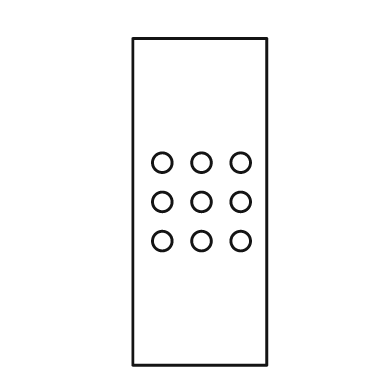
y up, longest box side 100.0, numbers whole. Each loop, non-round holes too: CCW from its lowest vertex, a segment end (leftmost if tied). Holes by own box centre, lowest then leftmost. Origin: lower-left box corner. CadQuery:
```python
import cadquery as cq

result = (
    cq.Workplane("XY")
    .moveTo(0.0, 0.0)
    .lineTo(41.0, 0.0)
    .lineTo(41.0, 100.0)
    .lineTo(0.0, 100.0)
    .close()
    .moveTo(9.0, 38.0)
    .circle(3.0)
    .moveTo(21.0, 38.0)
    .circle(3.0)
    .moveTo(33.0, 38.0)
    .circle(3.0)
    .moveTo(9.0, 50.0)
    .circle(3.0)
    .moveTo(21.0, 50.0)
    .circle(3.0)
    .moveTo(33.0, 50.0)
    .circle(3.0)
    .moveTo(9.0, 62.0)
    .circle(3.0)
    .moveTo(21.0, 62.0)
    .circle(3.0)
    .moveTo(33.0, 62.0)
    .circle(3.0)
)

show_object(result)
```